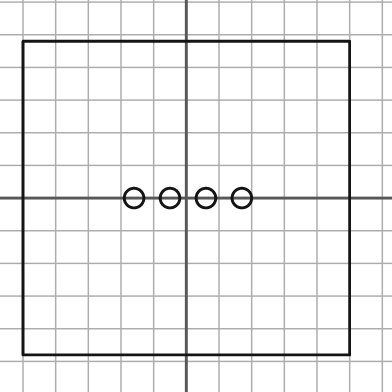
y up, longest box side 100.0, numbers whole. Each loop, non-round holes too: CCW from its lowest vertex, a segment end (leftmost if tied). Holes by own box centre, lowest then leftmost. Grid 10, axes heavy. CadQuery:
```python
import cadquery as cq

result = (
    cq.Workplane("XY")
    .moveTo(-50.0, -48.0)
    .lineTo(50.0, -48.0)
    .lineTo(50.0, 48.0)
    .lineTo(-50.0, 48.0)
    .close()
    .moveTo(-16.0, 0.0)
    .circle(3.0)
    .moveTo(-5.0, 0.0)
    .circle(3.0)
    .moveTo(6.0, 0.0)
    .circle(3.0)
    .moveTo(17.0, 0.0)
    .circle(3.0)
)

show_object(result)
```